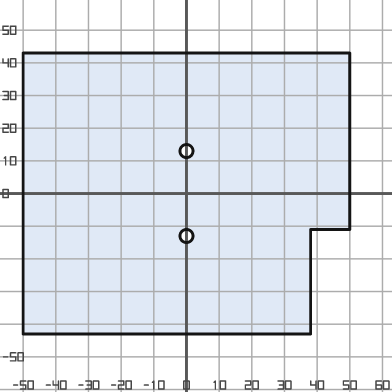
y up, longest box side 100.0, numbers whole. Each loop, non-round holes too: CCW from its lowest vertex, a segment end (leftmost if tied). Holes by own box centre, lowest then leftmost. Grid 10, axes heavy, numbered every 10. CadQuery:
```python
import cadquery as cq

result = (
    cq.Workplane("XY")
    .moveTo(-50.0, -43.0)
    .lineTo(38.0, -43.0)
    .lineTo(38.0, -11.0)
    .lineTo(50.0, -11.0)
    .lineTo(50.0, 43.0)
    .lineTo(-50.0, 43.0)
    .close()
    .moveTo(0.0, -13.0)
    .circle(2.0)
    .moveTo(0.0, 13.0)
    .circle(2.0)
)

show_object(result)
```